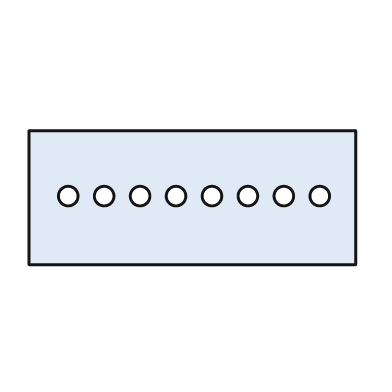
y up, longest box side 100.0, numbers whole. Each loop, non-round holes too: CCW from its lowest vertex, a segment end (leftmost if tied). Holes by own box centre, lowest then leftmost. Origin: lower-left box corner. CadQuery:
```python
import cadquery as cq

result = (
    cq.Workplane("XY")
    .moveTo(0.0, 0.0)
    .lineTo(100.0, 0.0)
    .lineTo(100.0, 41.0)
    .lineTo(0.0, 41.0)
    .close()
    .moveTo(12.0, 21.0)
    .circle(3.0)
    .moveTo(23.0, 21.0)
    .circle(3.0)
    .moveTo(34.0, 21.0)
    .circle(3.0)
    .moveTo(45.0, 21.0)
    .circle(3.0)
    .moveTo(56.0, 21.0)
    .circle(3.0)
    .moveTo(67.0, 21.0)
    .circle(3.0)
    .moveTo(78.0, 21.0)
    .circle(3.0)
    .moveTo(89.0, 21.0)
    .circle(3.0)
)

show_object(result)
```